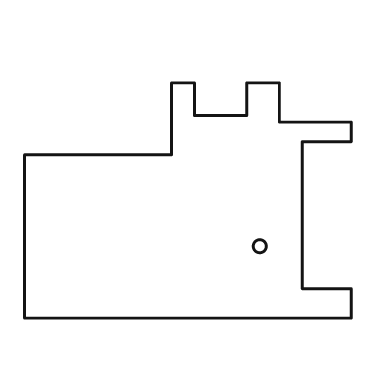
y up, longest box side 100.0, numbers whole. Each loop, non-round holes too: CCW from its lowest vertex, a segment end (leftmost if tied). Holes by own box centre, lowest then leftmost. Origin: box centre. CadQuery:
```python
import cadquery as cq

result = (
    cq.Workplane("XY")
    .moveTo(-50.0, -36.0)
    .lineTo(50.0, -36.0)
    .lineTo(50.0, -27.0)
    .lineTo(35.0, -27.0)
    .lineTo(35.0, 18.0)
    .lineTo(50.0, 18.0)
    .lineTo(50.0, 24.0)
    .lineTo(28.0, 24.0)
    .lineTo(28.0, 36.0)
    .lineTo(18.0, 36.0)
    .lineTo(18.0, 26.0)
    .lineTo(2.0, 26.0)
    .lineTo(2.0, 36.0)
    .lineTo(-5.0, 36.0)
    .lineTo(-5.0, 14.0)
    .lineTo(-50.0, 14.0)
    .close()
    .moveTo(22.0, -14.0)
    .circle(2.0)
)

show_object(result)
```